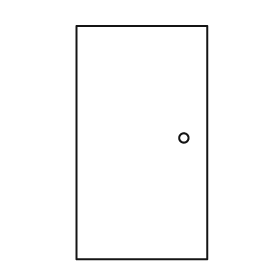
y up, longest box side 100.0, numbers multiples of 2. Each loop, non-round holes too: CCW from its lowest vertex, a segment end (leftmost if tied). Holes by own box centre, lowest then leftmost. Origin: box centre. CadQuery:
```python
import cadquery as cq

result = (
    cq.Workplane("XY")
    .moveTo(-28.0, -50.0)
    .lineTo(28.0, -50.0)
    .lineTo(28.0, 50.0)
    .lineTo(-28.0, 50.0)
    .close()
    .moveTo(18.0, 2.0)
    .circle(2.0)
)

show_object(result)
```